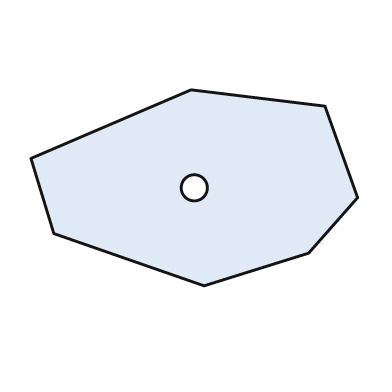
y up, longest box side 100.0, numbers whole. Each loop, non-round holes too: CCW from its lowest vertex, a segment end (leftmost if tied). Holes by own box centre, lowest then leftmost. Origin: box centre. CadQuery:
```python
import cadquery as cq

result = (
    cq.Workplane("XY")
    .moveTo(3.0, -30.0)
    .lineTo(35.0, -20.0)
    .lineTo(50.0, -3.0)
    .lineTo(40.0, 25.0)
    .lineTo(-1.0, 30.0)
    .lineTo(-50.0, 9.0)
    .lineTo(-43.0, -14.0)
    .close()
    .moveTo(0.0, 0.0)
    .circle(4.0)
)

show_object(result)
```